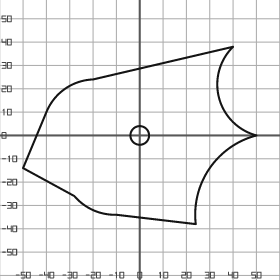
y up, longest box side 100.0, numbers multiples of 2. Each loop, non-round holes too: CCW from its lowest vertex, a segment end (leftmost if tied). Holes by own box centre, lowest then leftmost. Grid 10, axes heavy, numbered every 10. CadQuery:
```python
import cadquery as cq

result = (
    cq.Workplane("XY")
    .moveTo(24.0, -38.0)
    .threePointArc((30.0, -14.0), (50.0, 0.0))
    .threePointArc((34.0, 16.0), (40.0, 38.0))
    .lineTo(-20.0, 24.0)
    .threePointArc((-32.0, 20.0), (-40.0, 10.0))
    .lineTo(-50.0, -14.0)
    .lineTo(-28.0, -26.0)
    .threePointArc((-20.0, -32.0), (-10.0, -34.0))
    .close()
    .moveTo(0.0, 0.0)
    .circle(4.0)
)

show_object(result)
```